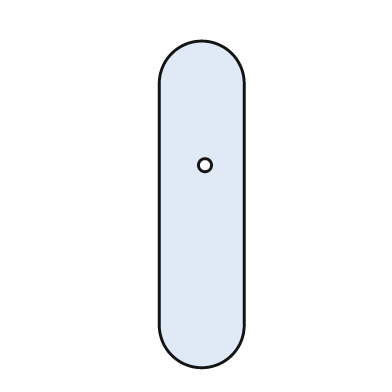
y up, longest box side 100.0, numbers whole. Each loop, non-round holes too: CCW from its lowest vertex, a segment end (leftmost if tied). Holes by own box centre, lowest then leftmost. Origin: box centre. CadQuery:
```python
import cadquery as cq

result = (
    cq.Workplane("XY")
    .moveTo(-13.0, -37.0)
    .threePointArc((0.0, -50.0), (13.0, -37.0))
    .lineTo(13.0, 37.0)
    .threePointArc((0.0, 50.0), (-13.0, 37.0))
    .close()
    .moveTo(1.0, 12.0)
    .circle(2.0)
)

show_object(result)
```